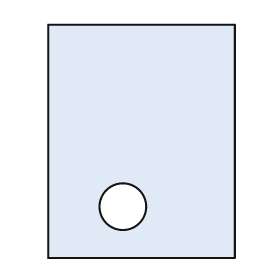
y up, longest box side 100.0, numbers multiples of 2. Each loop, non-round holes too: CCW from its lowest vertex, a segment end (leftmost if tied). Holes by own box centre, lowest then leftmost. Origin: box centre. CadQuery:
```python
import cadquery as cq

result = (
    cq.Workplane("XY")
    .moveTo(-40.0, -50.0)
    .lineTo(40.0, -50.0)
    .lineTo(40.0, 50.0)
    .lineTo(-40.0, 50.0)
    .close()
    .moveTo(-8.0, -28.0)
    .circle(10.0)
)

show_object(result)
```